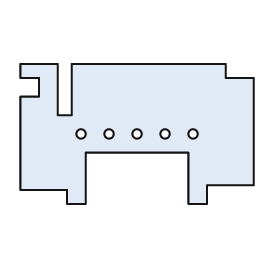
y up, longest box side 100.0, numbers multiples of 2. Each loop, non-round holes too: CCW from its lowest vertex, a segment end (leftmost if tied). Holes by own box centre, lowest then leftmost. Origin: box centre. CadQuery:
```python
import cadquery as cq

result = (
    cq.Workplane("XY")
    .moveTo(-30.0, -30.0)
    .lineTo(-22.0, -30.0)
    .lineTo(-22.0, -8.0)
    .lineTo(22.0, -8.0)
    .lineTo(22.0, -30.0)
    .lineTo(30.0, -30.0)
    .lineTo(30.0, -22.0)
    .lineTo(50.0, -22.0)
    .lineTo(50.0, 24.0)
    .lineTo(38.0, 24.0)
    .lineTo(38.0, 30.0)
    .lineTo(-28.0, 30.0)
    .lineTo(-28.0, 8.0)
    .lineTo(-34.0, 8.0)
    .lineTo(-34.0, 30.0)
    .lineTo(-50.0, 30.0)
    .lineTo(-50.0, 24.0)
    .lineTo(-42.0, 24.0)
    .lineTo(-42.0, 16.0)
    .lineTo(-50.0, 16.0)
    .lineTo(-50.0, -24.0)
    .lineTo(-30.0, -24.0)
    .close()
    .moveTo(-24.0, 0.0)
    .circle(2.0)
    .moveTo(-12.0, 0.0)
    .circle(2.0)
    .moveTo(0.0, 0.0)
    .circle(2.0)
    .moveTo(12.0, 0.0)
    .circle(2.0)
    .moveTo(24.0, 0.0)
    .circle(2.0)
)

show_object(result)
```